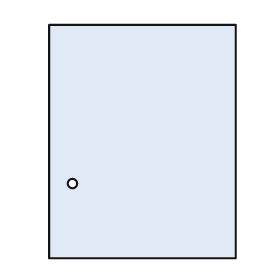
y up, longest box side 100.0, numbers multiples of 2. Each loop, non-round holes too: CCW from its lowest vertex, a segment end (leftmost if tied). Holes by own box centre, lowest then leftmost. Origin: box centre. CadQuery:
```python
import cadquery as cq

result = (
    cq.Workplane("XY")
    .moveTo(-40.0, -50.0)
    .lineTo(40.0, -50.0)
    .lineTo(40.0, 50.0)
    .lineTo(-40.0, 50.0)
    .close()
    .moveTo(-30.0, -18.0)
    .circle(2.0)
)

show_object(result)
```